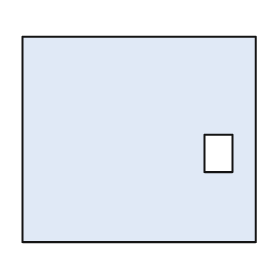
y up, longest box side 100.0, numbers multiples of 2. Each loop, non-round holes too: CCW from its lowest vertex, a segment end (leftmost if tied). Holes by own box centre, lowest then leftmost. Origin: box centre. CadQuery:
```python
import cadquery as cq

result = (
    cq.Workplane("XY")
    .moveTo(-50.0, -44.0)
    .lineTo(50.0, -44.0)
    .lineTo(50.0, 44.0)
    .lineTo(-50.0, 44.0)
    .close()
    .moveTo(28.0, -14.0)
    .lineTo(40.0, -14.0)
    .lineTo(40.0, 2.0)
    .lineTo(28.0, 2.0)
    .close()
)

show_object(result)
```